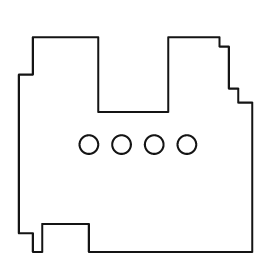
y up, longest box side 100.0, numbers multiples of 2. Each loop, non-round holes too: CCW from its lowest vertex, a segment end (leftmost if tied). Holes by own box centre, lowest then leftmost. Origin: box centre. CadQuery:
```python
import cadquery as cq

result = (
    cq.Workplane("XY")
    .moveTo(-44.0, -46.0)
    .lineTo(-40.0, -46.0)
    .lineTo(-40.0, -34.0)
    .lineTo(-20.0, -34.0)
    .lineTo(-20.0, -46.0)
    .lineTo(50.0, -46.0)
    .lineTo(50.0, 18.0)
    .lineTo(44.0, 18.0)
    .lineTo(44.0, 24.0)
    .lineTo(40.0, 24.0)
    .lineTo(40.0, 42.0)
    .lineTo(36.0, 42.0)
    .lineTo(36.0, 46.0)
    .lineTo(14.0, 46.0)
    .lineTo(14.0, 14.0)
    .lineTo(-16.0, 14.0)
    .lineTo(-16.0, 46.0)
    .lineTo(-44.0, 46.0)
    .lineTo(-44.0, 30.0)
    .lineTo(-50.0, 30.0)
    .lineTo(-50.0, -38.0)
    .lineTo(-44.0, -38.0)
    .close()
    .moveTo(-20.0, 0.0)
    .circle(4.0)
    .moveTo(-6.0, 0.0)
    .circle(4.0)
    .moveTo(8.0, 0.0)
    .circle(4.0)
    .moveTo(22.0, 0.0)
    .circle(4.0)
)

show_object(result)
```